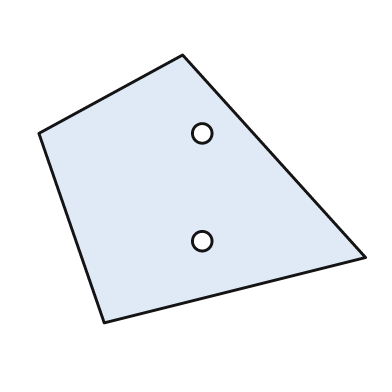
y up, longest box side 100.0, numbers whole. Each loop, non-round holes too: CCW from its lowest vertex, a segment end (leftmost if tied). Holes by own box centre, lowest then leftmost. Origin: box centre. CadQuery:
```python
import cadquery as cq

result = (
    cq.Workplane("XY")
    .moveTo(-30.0, -41.0)
    .lineTo(50.0, -21.0)
    .lineTo(-6.0, 41.0)
    .lineTo(-50.0, 17.0)
    .close()
    .moveTo(0.0, -16.0)
    .circle(3.0)
    .moveTo(0.0, 17.0)
    .circle(3.0)
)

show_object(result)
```